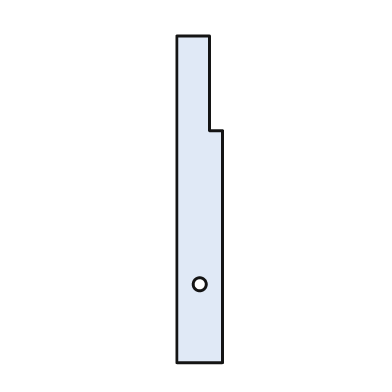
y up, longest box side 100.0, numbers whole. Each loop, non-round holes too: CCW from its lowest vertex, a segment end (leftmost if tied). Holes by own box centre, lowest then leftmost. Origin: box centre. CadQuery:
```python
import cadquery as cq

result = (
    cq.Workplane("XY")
    .moveTo(-7.0, -50.0)
    .lineTo(7.0, -50.0)
    .lineTo(7.0, 21.0)
    .lineTo(3.0, 21.0)
    .lineTo(3.0, 50.0)
    .lineTo(-7.0, 50.0)
    .close()
    .moveTo(0.0, -26.0)
    .circle(2.0)
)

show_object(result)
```